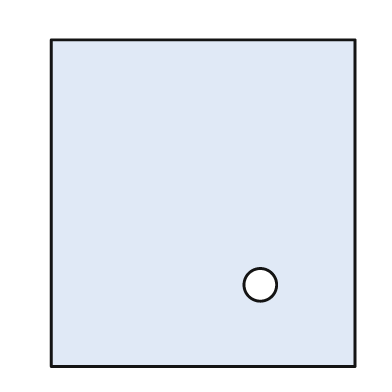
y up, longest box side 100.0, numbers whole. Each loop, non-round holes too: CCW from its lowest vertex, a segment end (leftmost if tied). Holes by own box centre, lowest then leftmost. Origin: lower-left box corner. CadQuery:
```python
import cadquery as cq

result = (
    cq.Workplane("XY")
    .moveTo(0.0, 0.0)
    .lineTo(93.0, 0.0)
    .lineTo(93.0, 100.0)
    .lineTo(0.0, 100.0)
    .close()
    .moveTo(64.0, 25.0)
    .circle(5.0)
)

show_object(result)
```